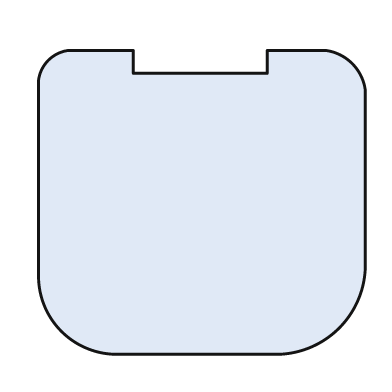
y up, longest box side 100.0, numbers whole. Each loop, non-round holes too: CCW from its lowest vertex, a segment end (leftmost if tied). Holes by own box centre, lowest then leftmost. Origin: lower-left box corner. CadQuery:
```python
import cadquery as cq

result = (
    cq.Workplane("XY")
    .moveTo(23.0, 0.0)
    .lineTo(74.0, 0.0)
    .threePointArc((92.0, 8.0), (100.0, 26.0))
    .lineTo(100.0, 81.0)
    .threePointArc((96.0, 89.0), (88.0, 93.0))
    .lineTo(70.0, 93.0)
    .lineTo(70.0, 86.0)
    .lineTo(29.0, 86.0)
    .lineTo(29.0, 93.0)
    .lineTo(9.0, 93.0)
    .threePointArc((3.0, 90.0), (0.0, 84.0))
    .lineTo(0.0, 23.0)
    .threePointArc((7.0, 7.0), (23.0, 0.0))
    .close()
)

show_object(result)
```